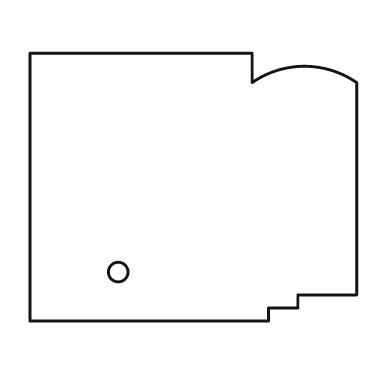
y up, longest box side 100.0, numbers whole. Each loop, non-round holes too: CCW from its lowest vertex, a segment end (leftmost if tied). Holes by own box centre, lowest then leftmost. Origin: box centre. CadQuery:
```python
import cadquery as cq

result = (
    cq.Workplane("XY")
    .moveTo(-50.0, -41.0)
    .lineTo(23.0, -41.0)
    .lineTo(23.0, -37.0)
    .lineTo(32.0, -37.0)
    .lineTo(32.0, -33.0)
    .lineTo(50.0, -33.0)
    .lineTo(50.0, 32.0)
    .threePointArc((34.0, 37.0), (18.0, 32.0))
    .lineTo(18.0, 41.0)
    .lineTo(-50.0, 41.0)
    .close()
    .moveTo(-23.0, -26.0)
    .circle(3.0)
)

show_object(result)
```